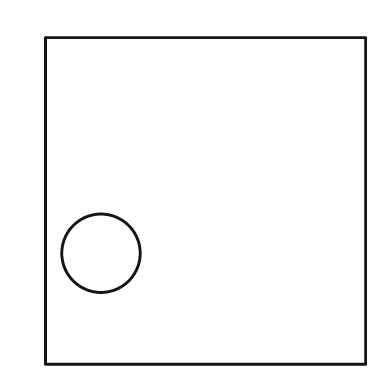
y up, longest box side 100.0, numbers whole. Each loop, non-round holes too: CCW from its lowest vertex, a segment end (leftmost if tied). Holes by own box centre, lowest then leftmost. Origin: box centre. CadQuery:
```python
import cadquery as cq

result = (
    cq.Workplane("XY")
    .moveTo(-49.0, -50.0)
    .lineTo(49.0, -50.0)
    .lineTo(49.0, 50.0)
    .lineTo(-49.0, 50.0)
    .close()
    .moveTo(-32.0, -16.0)
    .circle(12.0)
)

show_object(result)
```